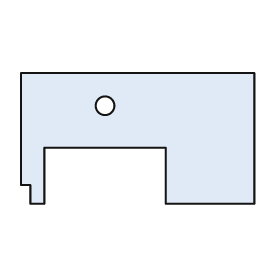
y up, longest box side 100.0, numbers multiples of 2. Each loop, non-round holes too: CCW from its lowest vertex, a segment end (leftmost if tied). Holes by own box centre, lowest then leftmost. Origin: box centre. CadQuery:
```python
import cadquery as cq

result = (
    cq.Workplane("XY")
    .moveTo(-46.0, -28.0)
    .lineTo(-40.0, -28.0)
    .lineTo(-40.0, -4.0)
    .lineTo(12.0, -4.0)
    .lineTo(12.0, -28.0)
    .lineTo(50.0, -28.0)
    .lineTo(50.0, 28.0)
    .lineTo(-50.0, 28.0)
    .lineTo(-50.0, -20.0)
    .lineTo(-46.0, -20.0)
    .close()
    .moveTo(-14.0, 14.0)
    .circle(4.0)
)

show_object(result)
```